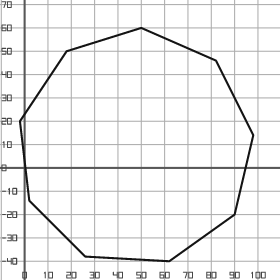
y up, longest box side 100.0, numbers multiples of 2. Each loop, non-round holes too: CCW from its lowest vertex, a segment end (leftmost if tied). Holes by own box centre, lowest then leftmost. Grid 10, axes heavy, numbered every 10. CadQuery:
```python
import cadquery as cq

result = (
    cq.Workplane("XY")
    .moveTo(62.0, -40.0)
    .lineTo(90.0, -20.0)
    .lineTo(98.0, 14.0)
    .lineTo(82.0, 46.0)
    .lineTo(50.0, 60.0)
    .lineTo(18.0, 50.0)
    .lineTo(-2.0, 20.0)
    .lineTo(2.0, -14.0)
    .lineTo(26.0, -38.0)
    .close()
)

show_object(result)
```